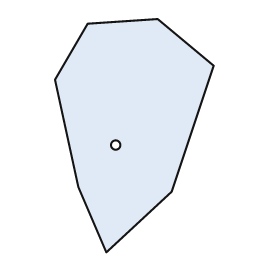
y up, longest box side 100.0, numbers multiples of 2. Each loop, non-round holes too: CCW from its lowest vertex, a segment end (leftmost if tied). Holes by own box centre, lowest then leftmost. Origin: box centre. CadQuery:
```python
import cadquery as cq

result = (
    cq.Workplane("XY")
    .moveTo(-12.0, -50.0)
    .lineTo(16.0, -24.0)
    .lineTo(34.0, 30.0)
    .lineTo(10.0, 50.0)
    .lineTo(-20.0, 48.0)
    .lineTo(-34.0, 24.0)
    .lineTo(-24.0, -22.0)
    .close()
    .moveTo(-8.0, -4.0)
    .circle(2.0)
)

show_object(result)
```